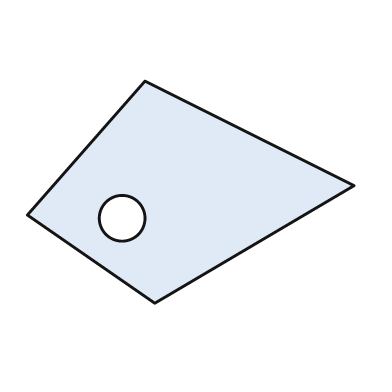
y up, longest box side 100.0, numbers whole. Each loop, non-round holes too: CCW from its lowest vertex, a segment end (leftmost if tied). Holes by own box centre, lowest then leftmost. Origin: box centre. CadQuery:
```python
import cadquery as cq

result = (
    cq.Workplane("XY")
    .moveTo(-11.0, -34.0)
    .lineTo(50.0, 2.0)
    .lineTo(-14.0, 34.0)
    .lineTo(-50.0, -7.0)
    .close()
    .moveTo(-21.0, -8.0)
    .circle(7.0)
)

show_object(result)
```